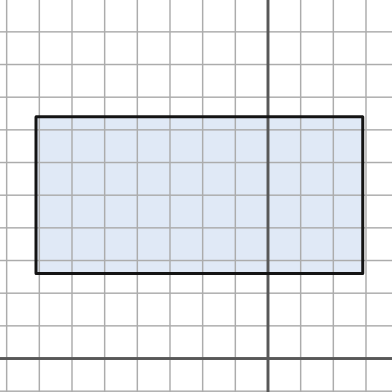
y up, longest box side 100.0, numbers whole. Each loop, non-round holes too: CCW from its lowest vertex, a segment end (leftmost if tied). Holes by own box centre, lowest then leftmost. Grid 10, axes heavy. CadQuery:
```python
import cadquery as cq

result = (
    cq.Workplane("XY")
    .moveTo(-71.0, 26.0)
    .lineTo(29.0, 26.0)
    .lineTo(29.0, 74.0)
    .lineTo(-71.0, 74.0)
    .close()
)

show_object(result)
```